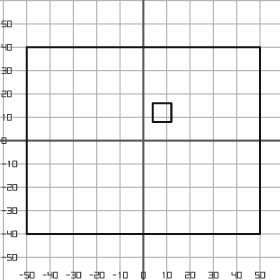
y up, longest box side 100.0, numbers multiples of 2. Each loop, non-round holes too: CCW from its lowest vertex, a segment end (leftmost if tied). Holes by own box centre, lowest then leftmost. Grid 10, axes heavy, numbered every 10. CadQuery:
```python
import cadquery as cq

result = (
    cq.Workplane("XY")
    .moveTo(-50.0, -40.0)
    .lineTo(50.0, -40.0)
    .lineTo(50.0, 40.0)
    .lineTo(-50.0, 40.0)
    .close()
    .moveTo(4.0, 8.0)
    .lineTo(12.0, 8.0)
    .lineTo(12.0, 16.0)
    .lineTo(4.0, 16.0)
    .close()
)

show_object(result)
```